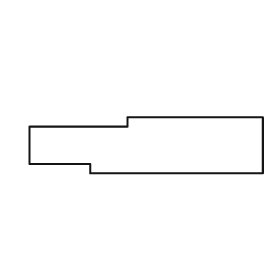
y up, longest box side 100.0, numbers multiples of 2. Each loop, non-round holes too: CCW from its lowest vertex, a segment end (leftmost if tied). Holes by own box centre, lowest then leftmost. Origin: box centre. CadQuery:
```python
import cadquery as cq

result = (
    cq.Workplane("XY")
    .moveTo(-24.0, -12.0)
    .lineTo(50.0, -12.0)
    .lineTo(50.0, 12.0)
    .lineTo(-8.0, 12.0)
    .lineTo(-8.0, 8.0)
    .lineTo(-50.0, 8.0)
    .lineTo(-50.0, -8.0)
    .lineTo(-24.0, -8.0)
    .close()
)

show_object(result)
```